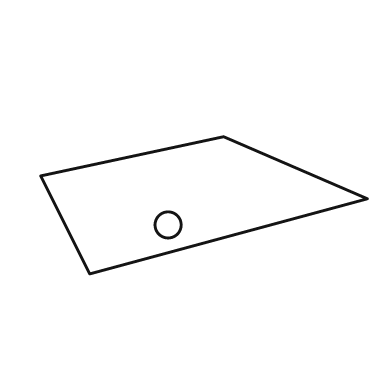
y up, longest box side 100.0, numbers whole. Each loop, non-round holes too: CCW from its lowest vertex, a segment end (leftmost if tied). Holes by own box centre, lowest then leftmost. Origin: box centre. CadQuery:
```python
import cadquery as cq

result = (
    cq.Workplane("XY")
    .moveTo(-35.0, -21.0)
    .lineTo(50.0, 2.0)
    .lineTo(6.0, 21.0)
    .lineTo(-50.0, 9.0)
    .close()
    .moveTo(-11.0, -6.0)
    .circle(4.0)
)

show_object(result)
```